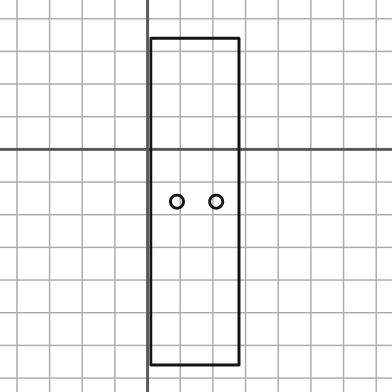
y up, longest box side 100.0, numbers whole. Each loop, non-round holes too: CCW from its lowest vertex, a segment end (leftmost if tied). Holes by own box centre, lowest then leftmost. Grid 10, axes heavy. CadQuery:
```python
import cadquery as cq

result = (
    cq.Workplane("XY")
    .moveTo(1.0, -66.0)
    .lineTo(28.0, -66.0)
    .lineTo(28.0, 34.0)
    .lineTo(1.0, 34.0)
    .close()
    .moveTo(9.0, -16.0)
    .circle(2.0)
    .moveTo(21.0, -16.0)
    .circle(2.0)
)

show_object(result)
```